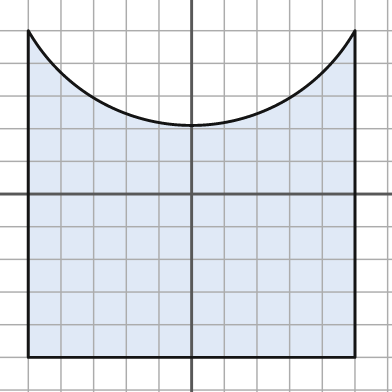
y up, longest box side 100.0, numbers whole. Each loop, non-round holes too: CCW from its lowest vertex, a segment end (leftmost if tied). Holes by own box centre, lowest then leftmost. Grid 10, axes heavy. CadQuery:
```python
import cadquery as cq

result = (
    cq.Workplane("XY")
    .moveTo(-50.0, -50.0)
    .lineTo(50.0, -50.0)
    .lineTo(50.0, 50.0)
    .threePointArc((0.0, 21.0), (-50.0, 50.0))
    .close()
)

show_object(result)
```